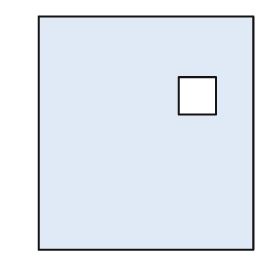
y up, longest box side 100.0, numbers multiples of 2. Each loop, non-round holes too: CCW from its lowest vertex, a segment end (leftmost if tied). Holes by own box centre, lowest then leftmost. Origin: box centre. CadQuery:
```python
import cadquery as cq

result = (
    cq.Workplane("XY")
    .moveTo(-46.0, -50.0)
    .lineTo(46.0, -50.0)
    .lineTo(46.0, 50.0)
    .lineTo(-46.0, 50.0)
    .close()
    .moveTo(14.0, 8.0)
    .lineTo(30.0, 8.0)
    .lineTo(30.0, 24.0)
    .lineTo(14.0, 24.0)
    .close()
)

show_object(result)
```